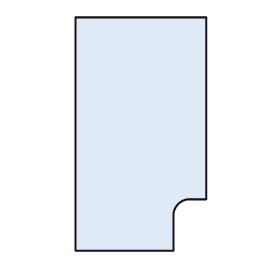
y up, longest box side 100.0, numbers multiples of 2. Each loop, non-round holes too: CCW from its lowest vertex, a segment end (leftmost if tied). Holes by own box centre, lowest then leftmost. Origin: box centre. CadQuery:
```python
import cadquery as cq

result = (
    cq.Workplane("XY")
    .moveTo(-28.0, -50.0)
    .lineTo(14.0, -50.0)
    .lineTo(14.0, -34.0)
    .threePointArc((16.0, -30.0), (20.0, -28.0))
    .lineTo(28.0, -28.0)
    .lineTo(28.0, 50.0)
    .lineTo(-28.0, 50.0)
    .close()
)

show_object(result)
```